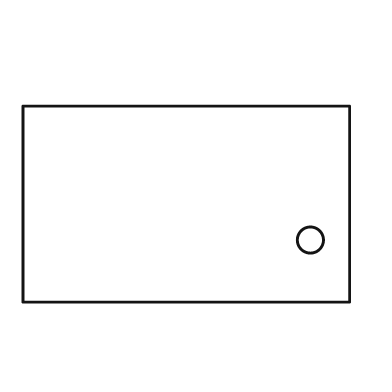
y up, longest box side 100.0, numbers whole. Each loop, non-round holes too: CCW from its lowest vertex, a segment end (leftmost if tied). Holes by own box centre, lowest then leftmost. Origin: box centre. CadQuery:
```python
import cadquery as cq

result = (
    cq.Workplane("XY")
    .moveTo(-50.0, -30.0)
    .lineTo(50.0, -30.0)
    .lineTo(50.0, 30.0)
    .lineTo(-50.0, 30.0)
    .close()
    .moveTo(38.0, -11.0)
    .circle(4.0)
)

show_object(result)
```